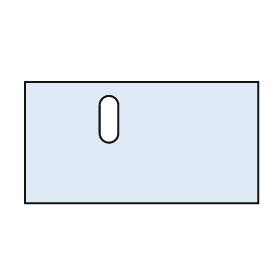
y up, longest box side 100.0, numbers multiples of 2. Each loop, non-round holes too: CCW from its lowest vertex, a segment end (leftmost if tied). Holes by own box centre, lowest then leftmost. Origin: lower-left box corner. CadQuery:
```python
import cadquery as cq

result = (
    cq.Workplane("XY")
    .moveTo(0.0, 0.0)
    .lineTo(100.0, 0.0)
    .lineTo(100.0, 52.0)
    .lineTo(0.0, 52.0)
    .close()
    .moveTo(32.0, 30.0)
    .threePointArc((36.0, 26.0), (40.0, 30.0))
    .lineTo(40.0, 42.0)
    .threePointArc((36.0, 46.0), (32.0, 42.0))
    .close()
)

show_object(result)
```